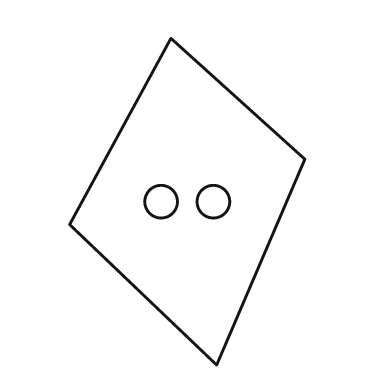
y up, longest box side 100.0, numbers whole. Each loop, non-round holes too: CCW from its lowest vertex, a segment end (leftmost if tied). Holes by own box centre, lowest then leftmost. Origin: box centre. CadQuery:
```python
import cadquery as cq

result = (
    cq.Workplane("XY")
    .moveTo(9.0, -50.0)
    .lineTo(36.0, 13.0)
    .lineTo(-5.0, 50.0)
    .lineTo(-36.0, -7.0)
    .close()
    .moveTo(-8.0, 0.0)
    .circle(5.0)
    .moveTo(8.0, 0.0)
    .circle(5.0)
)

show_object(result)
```